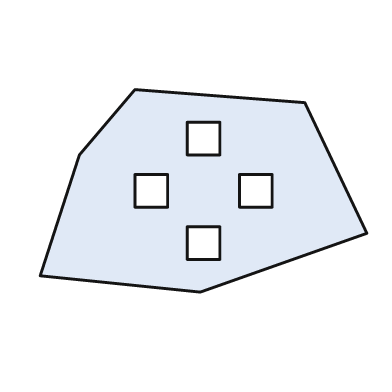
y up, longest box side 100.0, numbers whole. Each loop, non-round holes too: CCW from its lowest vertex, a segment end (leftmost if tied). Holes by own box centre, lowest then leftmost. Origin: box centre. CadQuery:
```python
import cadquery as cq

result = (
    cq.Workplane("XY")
    .moveTo(-1.0, -31.0)
    .lineTo(50.0, -13.0)
    .lineTo(31.0, 27.0)
    .lineTo(-21.0, 31.0)
    .lineTo(-38.0, 11.0)
    .lineTo(-50.0, -26.0)
    .close()
    .moveTo(-5.0, -21.0)
    .lineTo(5.0, -21.0)
    .lineTo(5.0, -11.0)
    .lineTo(-5.0, -11.0)
    .close()
    .moveTo(-21.0, -5.0)
    .lineTo(-11.0, -5.0)
    .lineTo(-11.0, 5.0)
    .lineTo(-21.0, 5.0)
    .close()
    .moveTo(11.0, -5.0)
    .lineTo(21.0, -5.0)
    .lineTo(21.0, 5.0)
    .lineTo(11.0, 5.0)
    .close()
    .moveTo(-5.0, 11.0)
    .lineTo(5.0, 11.0)
    .lineTo(5.0, 21.0)
    .lineTo(-5.0, 21.0)
    .close()
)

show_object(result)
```